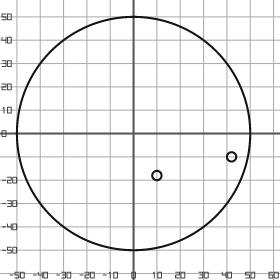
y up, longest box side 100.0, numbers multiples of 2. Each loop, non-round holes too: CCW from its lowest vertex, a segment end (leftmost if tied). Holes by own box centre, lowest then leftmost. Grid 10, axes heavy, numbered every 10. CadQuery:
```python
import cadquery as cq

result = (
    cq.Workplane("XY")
    .moveTo(0.0, 0.0)
    .circle(50.0)
    .moveTo(10.0, -18.0)
    .circle(2.0)
    .moveTo(42.0, -10.0)
    .circle(2.0)
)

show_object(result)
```